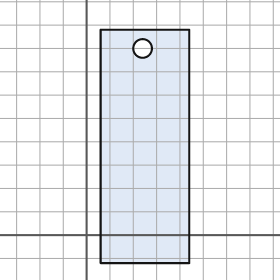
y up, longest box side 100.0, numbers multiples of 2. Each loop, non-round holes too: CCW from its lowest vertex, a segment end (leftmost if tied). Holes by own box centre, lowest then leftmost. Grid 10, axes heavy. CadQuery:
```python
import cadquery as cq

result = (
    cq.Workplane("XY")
    .moveTo(6.0, -12.0)
    .lineTo(44.0, -12.0)
    .lineTo(44.0, 88.0)
    .lineTo(6.0, 88.0)
    .close()
    .moveTo(24.0, 80.0)
    .circle(4.0)
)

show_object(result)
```